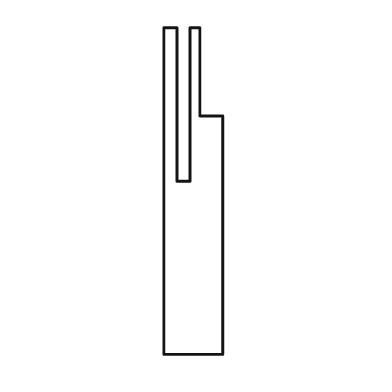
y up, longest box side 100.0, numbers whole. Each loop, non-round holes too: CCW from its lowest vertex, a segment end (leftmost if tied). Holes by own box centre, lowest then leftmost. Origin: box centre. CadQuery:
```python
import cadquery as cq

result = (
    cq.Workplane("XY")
    .moveTo(-9.0, -50.0)
    .lineTo(9.0, -50.0)
    .lineTo(9.0, 23.0)
    .lineTo(2.0, 23.0)
    .lineTo(2.0, 50.0)
    .lineTo(-1.0, 50.0)
    .lineTo(-1.0, 3.0)
    .lineTo(-5.0, 3.0)
    .lineTo(-5.0, 50.0)
    .lineTo(-9.0, 50.0)
    .close()
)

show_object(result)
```